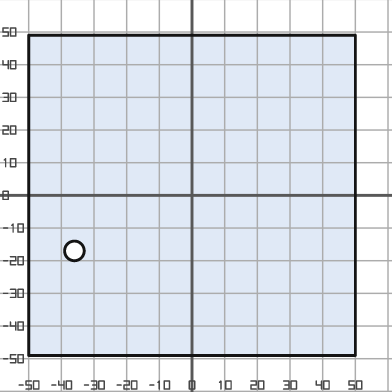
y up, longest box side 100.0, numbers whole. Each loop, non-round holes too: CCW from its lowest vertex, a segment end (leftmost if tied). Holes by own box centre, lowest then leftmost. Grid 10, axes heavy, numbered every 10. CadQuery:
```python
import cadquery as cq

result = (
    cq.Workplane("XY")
    .moveTo(-50.0, -49.0)
    .lineTo(50.0, -49.0)
    .lineTo(50.0, 49.0)
    .lineTo(-50.0, 49.0)
    .close()
    .moveTo(-36.0, -17.0)
    .circle(3.0)
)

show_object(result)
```